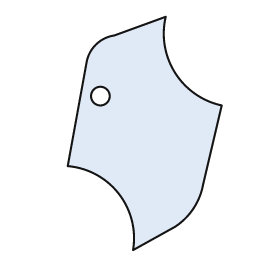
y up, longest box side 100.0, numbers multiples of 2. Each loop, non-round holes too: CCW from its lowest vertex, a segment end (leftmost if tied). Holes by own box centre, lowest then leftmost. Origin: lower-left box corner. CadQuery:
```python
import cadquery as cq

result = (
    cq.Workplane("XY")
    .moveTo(28.0, 0.0)
    .lineTo(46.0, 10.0)
    .threePointArc((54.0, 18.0), (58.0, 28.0))
    .lineTo(66.0, 62.0)
    .threePointArc((46.0, 76.0), (42.0, 100.0))
    .lineTo(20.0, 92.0)
    .threePointArc((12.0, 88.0), (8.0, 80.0))
    .lineTo(0.0, 36.0)
    .threePointArc((22.0, 24.0), (28.0, 0.0))
    .close()
    .moveTo(14.0, 66.0)
    .circle(4.0)
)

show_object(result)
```